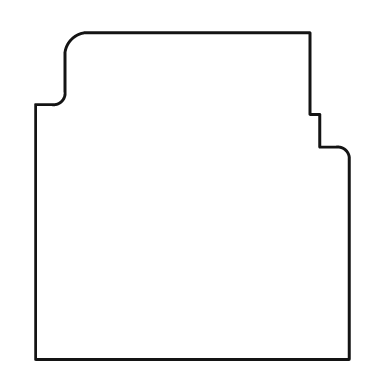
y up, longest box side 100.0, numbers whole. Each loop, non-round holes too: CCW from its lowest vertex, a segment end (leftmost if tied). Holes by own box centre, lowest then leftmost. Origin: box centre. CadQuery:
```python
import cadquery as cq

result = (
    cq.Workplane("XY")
    .moveTo(-48.0, -50.0)
    .lineTo(48.0, -50.0)
    .lineTo(48.0, 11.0)
    .threePointArc((47.0, 14.0), (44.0, 15.0))
    .lineTo(39.0, 15.0)
    .lineTo(39.0, 25.0)
    .lineTo(36.0, 25.0)
    .lineTo(36.0, 50.0)
    .lineTo(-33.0, 50.0)
    .threePointArc((-37.0, 48.0), (-39.0, 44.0))
    .lineTo(-39.0, 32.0)
    .threePointArc((-40.0, 29.0), (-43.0, 28.0))
    .lineTo(-48.0, 28.0)
    .close()
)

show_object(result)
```